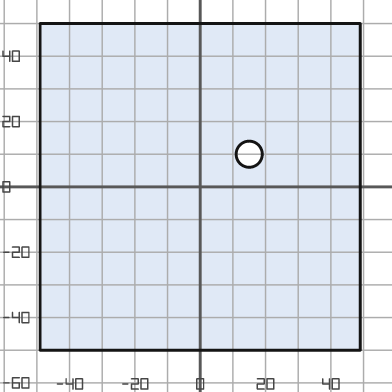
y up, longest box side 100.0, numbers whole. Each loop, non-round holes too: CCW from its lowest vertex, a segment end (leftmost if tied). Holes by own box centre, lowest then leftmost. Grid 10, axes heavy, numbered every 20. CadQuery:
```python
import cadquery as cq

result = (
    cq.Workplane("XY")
    .moveTo(-49.0, -50.0)
    .lineTo(49.0, -50.0)
    .lineTo(49.0, 50.0)
    .lineTo(-49.0, 50.0)
    .close()
    .moveTo(15.0, 10.0)
    .circle(4.0)
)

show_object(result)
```